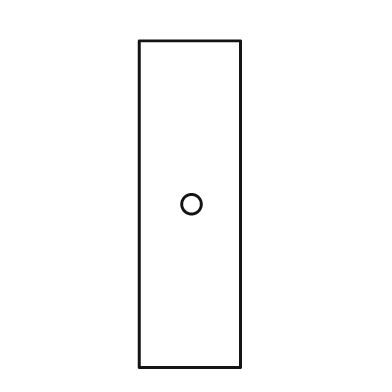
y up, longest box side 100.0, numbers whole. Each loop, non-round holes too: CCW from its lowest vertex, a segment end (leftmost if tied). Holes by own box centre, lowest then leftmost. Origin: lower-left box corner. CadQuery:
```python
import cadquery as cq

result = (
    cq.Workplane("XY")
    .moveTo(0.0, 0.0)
    .lineTo(31.0, 0.0)
    .lineTo(31.0, 100.0)
    .lineTo(0.0, 100.0)
    .close()
    .moveTo(16.0, 50.0)
    .circle(3.0)
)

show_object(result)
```